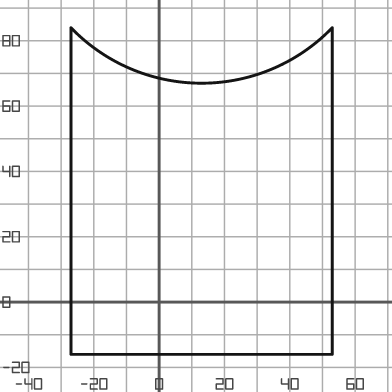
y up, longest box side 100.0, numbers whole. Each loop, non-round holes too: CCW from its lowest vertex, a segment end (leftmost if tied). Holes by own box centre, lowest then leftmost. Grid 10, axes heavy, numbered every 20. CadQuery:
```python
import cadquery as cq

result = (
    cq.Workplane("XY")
    .moveTo(-27.0, -16.0)
    .lineTo(53.0, -16.0)
    .lineTo(53.0, 84.0)
    .threePointArc((13.0, 67.0), (-27.0, 84.0))
    .close()
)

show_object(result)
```